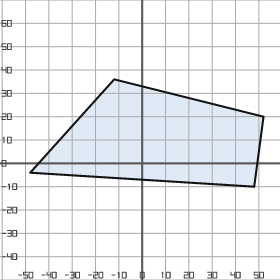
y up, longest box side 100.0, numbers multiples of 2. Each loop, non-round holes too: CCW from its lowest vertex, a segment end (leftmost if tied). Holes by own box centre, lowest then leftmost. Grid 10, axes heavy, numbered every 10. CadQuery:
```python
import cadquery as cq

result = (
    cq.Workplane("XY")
    .moveTo(48.0, -10.0)
    .lineTo(52.0, 20.0)
    .lineTo(-12.0, 36.0)
    .lineTo(-48.0, -4.0)
    .close()
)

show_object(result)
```